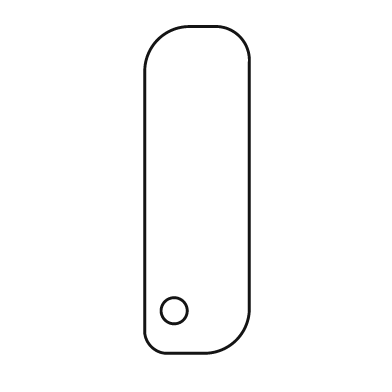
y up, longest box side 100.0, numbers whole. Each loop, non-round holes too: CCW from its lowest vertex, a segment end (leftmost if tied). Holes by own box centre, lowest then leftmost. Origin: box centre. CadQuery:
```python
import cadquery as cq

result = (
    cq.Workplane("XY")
    .moveTo(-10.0, -50.0)
    .lineTo(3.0, -50.0)
    .threePointArc((12.0, -46.0), (16.0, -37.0))
    .lineTo(16.0, 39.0)
    .threePointArc((13.0, 47.0), (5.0, 50.0))
    .lineTo(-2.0, 50.0)
    .threePointArc((-12.0, 46.0), (-16.0, 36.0))
    .lineTo(-16.0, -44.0)
    .threePointArc((-14.0, -48.0), (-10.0, -50.0))
    .close()
    .moveTo(-7.0, -37.0)
    .circle(4.0)
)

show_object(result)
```